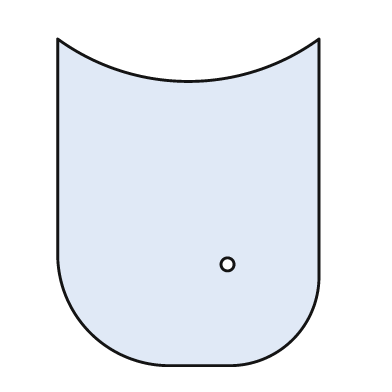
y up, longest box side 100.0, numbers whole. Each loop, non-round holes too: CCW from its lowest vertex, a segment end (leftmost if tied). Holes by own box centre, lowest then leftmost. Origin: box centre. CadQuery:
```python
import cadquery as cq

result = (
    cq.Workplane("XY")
    .moveTo(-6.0, -50.0)
    .lineTo(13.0, -50.0)
    .threePointArc((32.0, -42.0), (40.0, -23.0))
    .lineTo(40.0, 50.0)
    .threePointArc((0.0, 37.0), (-40.0, 50.0))
    .lineTo(-40.0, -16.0)
    .threePointArc((-30.0, -40.0), (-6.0, -50.0))
    .close()
    .moveTo(12.0, -19.0)
    .circle(2.0)
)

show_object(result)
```